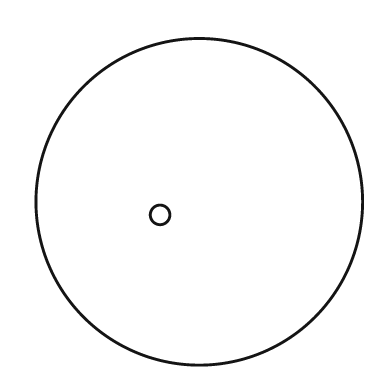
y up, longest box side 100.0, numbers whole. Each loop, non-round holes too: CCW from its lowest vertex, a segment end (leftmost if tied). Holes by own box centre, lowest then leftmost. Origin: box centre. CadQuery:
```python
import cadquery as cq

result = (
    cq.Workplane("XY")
    .moveTo(0.0, 0.0)
    .circle(50.0)
    .moveTo(-12.0, -4.0)
    .circle(3.0)
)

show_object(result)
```